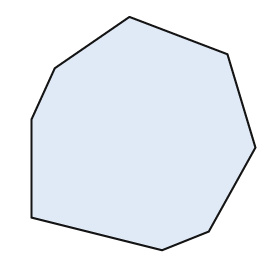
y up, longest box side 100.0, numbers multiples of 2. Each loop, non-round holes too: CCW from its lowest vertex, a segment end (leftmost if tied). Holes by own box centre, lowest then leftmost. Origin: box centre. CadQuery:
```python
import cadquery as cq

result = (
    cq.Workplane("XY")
    .moveTo(8.0, -50.0)
    .lineTo(28.0, -42.0)
    .lineTo(48.0, -6.0)
    .lineTo(36.0, 34.0)
    .lineTo(-6.0, 50.0)
    .lineTo(-38.0, 28.0)
    .lineTo(-48.0, 6.0)
    .lineTo(-48.0, -36.0)
    .close()
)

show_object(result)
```